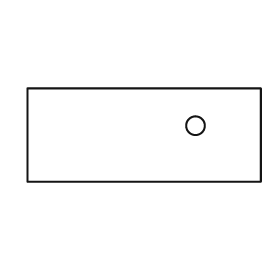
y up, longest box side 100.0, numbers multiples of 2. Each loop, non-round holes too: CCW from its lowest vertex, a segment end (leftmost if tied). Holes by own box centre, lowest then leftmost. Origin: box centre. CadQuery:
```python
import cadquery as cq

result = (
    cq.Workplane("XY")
    .moveTo(-50.0, -20.0)
    .lineTo(50.0, -20.0)
    .lineTo(50.0, 20.0)
    .lineTo(-50.0, 20.0)
    .close()
    .moveTo(22.0, 4.0)
    .circle(4.0)
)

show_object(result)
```